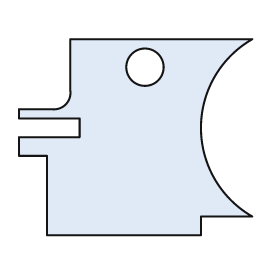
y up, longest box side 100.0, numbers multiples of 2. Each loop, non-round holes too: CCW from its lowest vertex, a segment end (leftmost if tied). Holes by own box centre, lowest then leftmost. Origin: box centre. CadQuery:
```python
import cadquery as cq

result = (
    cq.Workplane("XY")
    .moveTo(-38.0, -42.0)
    .lineTo(28.0, -42.0)
    .lineTo(28.0, -34.0)
    .lineTo(50.0, -34.0)
    .threePointArc((28.0, 4.0), (50.0, 42.0))
    .lineTo(-28.0, 42.0)
    .lineTo(-28.0, 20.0)
    .threePointArc((-30.0, 14.0), (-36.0, 12.0))
    .lineTo(-50.0, 12.0)
    .lineTo(-50.0, 8.0)
    .lineTo(-24.0, 8.0)
    .lineTo(-24.0, 0.0)
    .lineTo(-50.0, 0.0)
    .lineTo(-50.0, -8.0)
    .lineTo(-38.0, -8.0)
    .close()
    .moveTo(4.0, 30.0)
    .circle(8.0)
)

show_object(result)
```